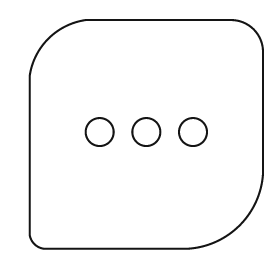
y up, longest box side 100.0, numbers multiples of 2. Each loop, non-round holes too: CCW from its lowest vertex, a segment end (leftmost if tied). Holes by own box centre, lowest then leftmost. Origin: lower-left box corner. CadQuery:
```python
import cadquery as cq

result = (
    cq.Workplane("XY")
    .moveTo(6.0, 0.0)
    .lineTo(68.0, 0.0)
    .threePointArc((90.0, 10.0), (100.0, 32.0))
    .lineTo(100.0, 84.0)
    .threePointArc((96.0, 94.0), (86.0, 98.0))
    .lineTo(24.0, 98.0)
    .threePointArc((8.0, 90.0), (0.0, 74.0))
    .lineTo(0.0, 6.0)
    .threePointArc((2.0, 2.0), (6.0, 0.0))
    .close()
    .moveTo(30.0, 50.0)
    .circle(6.0)
    .moveTo(50.0, 50.0)
    .circle(6.0)
    .moveTo(70.0, 50.0)
    .circle(6.0)
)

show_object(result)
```